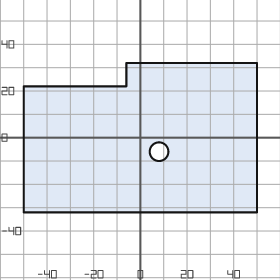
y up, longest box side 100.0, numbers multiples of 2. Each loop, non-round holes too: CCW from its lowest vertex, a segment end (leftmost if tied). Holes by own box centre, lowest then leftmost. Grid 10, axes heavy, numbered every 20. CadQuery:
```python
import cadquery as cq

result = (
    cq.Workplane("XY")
    .moveTo(-50.0, -32.0)
    .lineTo(50.0, -32.0)
    .lineTo(50.0, 32.0)
    .lineTo(-6.0, 32.0)
    .lineTo(-6.0, 22.0)
    .lineTo(-50.0, 22.0)
    .close()
    .moveTo(8.0, -6.0)
    .circle(4.0)
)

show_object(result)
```